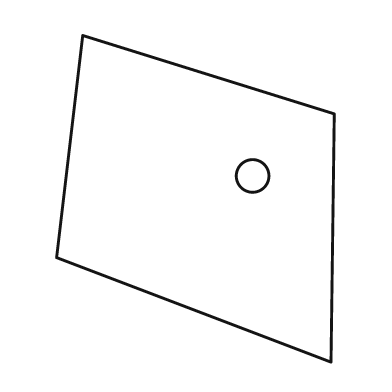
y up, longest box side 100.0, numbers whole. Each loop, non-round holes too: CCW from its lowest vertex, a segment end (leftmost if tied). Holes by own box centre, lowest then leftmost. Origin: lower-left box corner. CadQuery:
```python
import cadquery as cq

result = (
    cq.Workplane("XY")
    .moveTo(84.0, 0.0)
    .lineTo(85.0, 76.0)
    .lineTo(8.0, 100.0)
    .lineTo(0.0, 32.0)
    .close()
    .moveTo(60.0, 57.0)
    .circle(5.0)
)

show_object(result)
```